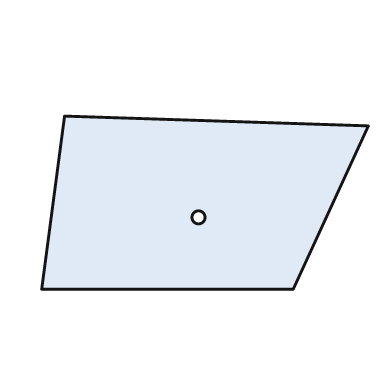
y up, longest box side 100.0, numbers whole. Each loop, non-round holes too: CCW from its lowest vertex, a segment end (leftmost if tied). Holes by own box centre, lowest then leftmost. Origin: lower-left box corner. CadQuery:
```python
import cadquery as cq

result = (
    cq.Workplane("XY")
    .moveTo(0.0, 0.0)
    .lineTo(77.0, 0.0)
    .lineTo(100.0, 50.0)
    .lineTo(7.0, 53.0)
    .close()
    .moveTo(48.0, 22.0)
    .circle(2.0)
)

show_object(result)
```